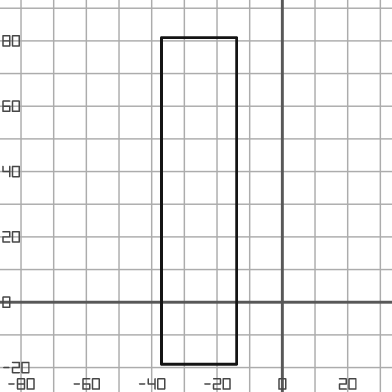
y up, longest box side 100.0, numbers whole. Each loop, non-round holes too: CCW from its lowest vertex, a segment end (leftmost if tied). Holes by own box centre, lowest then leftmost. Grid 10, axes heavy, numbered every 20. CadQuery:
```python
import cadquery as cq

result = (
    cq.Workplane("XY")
    .moveTo(-37.0, -19.0)
    .lineTo(-14.0, -19.0)
    .lineTo(-14.0, 81.0)
    .lineTo(-37.0, 81.0)
    .close()
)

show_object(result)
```